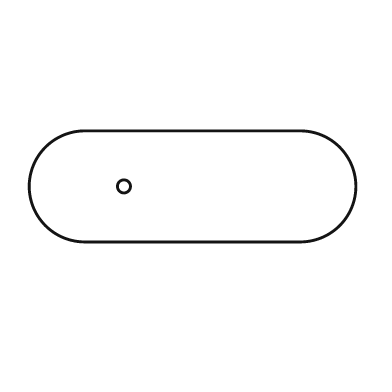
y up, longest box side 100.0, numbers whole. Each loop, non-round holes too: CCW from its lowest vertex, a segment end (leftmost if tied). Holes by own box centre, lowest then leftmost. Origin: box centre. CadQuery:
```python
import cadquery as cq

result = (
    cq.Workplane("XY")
    .moveTo(-33.0, -17.0)
    .lineTo(33.0, -17.0)
    .threePointArc((50.0, 0.0), (33.0, 17.0))
    .lineTo(-33.0, 17.0)
    .threePointArc((-50.0, 0.0), (-33.0, -17.0))
    .close()
    .moveTo(-21.0, 0.0)
    .circle(2.0)
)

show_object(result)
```